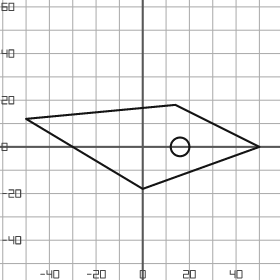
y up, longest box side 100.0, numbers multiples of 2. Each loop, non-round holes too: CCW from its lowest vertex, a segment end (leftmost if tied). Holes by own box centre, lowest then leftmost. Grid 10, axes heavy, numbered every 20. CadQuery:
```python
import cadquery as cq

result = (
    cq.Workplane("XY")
    .moveTo(0.0, -18.0)
    .lineTo(50.0, 0.0)
    .lineTo(14.0, 18.0)
    .lineTo(-50.0, 12.0)
    .close()
    .moveTo(16.0, 0.0)
    .circle(4.0)
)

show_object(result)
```